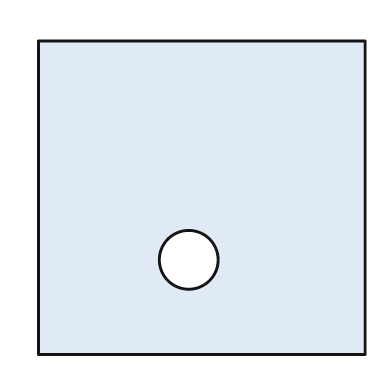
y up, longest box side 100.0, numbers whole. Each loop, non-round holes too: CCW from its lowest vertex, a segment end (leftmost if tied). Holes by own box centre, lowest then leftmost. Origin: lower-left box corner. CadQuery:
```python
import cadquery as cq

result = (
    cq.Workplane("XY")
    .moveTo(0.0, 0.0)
    .lineTo(100.0, 0.0)
    .lineTo(100.0, 96.0)
    .lineTo(0.0, 96.0)
    .close()
    .moveTo(46.0, 29.0)
    .circle(9.0)
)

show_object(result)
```